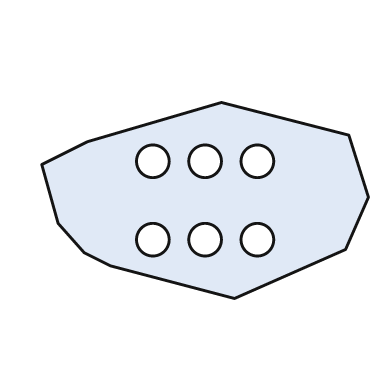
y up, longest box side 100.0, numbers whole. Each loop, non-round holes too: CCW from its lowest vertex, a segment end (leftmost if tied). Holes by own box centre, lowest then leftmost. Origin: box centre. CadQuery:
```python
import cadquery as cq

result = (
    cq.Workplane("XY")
    .moveTo(9.0, -30.0)
    .lineTo(43.0, -15.0)
    .lineTo(50.0, 1.0)
    .lineTo(44.0, 20.0)
    .lineTo(5.0, 30.0)
    .lineTo(-36.0, 18.0)
    .lineTo(-50.0, 11.0)
    .lineTo(-45.0, -7.0)
    .lineTo(-37.0, -16.0)
    .lineTo(-29.0, -20.0)
    .close()
    .moveTo(-16.0, -12.0)
    .circle(5.0)
    .moveTo(0.0, -12.0)
    .circle(5.0)
    .moveTo(16.0, -12.0)
    .circle(5.0)
    .moveTo(-16.0, 12.0)
    .circle(5.0)
    .moveTo(0.0, 12.0)
    .circle(5.0)
    .moveTo(16.0, 12.0)
    .circle(5.0)
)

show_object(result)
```